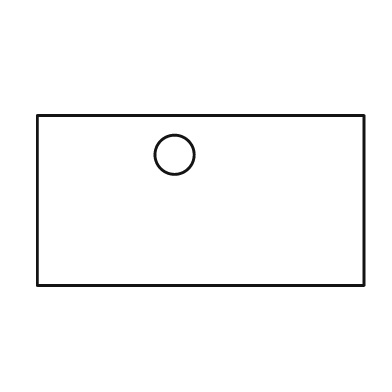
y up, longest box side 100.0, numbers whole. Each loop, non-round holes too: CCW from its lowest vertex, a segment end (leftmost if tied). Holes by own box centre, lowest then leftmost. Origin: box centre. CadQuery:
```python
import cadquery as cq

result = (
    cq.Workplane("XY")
    .moveTo(-50.0, -26.0)
    .lineTo(50.0, -26.0)
    .lineTo(50.0, 26.0)
    .lineTo(-50.0, 26.0)
    .close()
    .moveTo(-8.0, 14.0)
    .circle(6.0)
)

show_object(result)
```